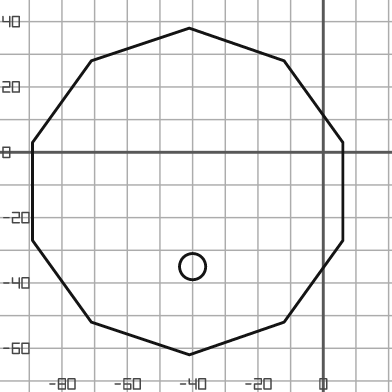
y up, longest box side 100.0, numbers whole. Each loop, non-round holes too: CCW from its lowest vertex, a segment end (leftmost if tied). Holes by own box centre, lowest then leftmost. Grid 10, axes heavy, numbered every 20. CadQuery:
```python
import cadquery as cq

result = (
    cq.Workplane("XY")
    .moveTo(-41.0, -62.0)
    .lineTo(-12.0, -52.0)
    .lineTo(6.0, -27.0)
    .lineTo(6.0, 3.0)
    .lineTo(-12.0, 28.0)
    .lineTo(-41.0, 38.0)
    .lineTo(-71.0, 28.0)
    .lineTo(-89.0, 3.0)
    .lineTo(-89.0, -27.0)
    .lineTo(-71.0, -52.0)
    .close()
    .moveTo(-40.0, -35.0)
    .circle(4.0)
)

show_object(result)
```